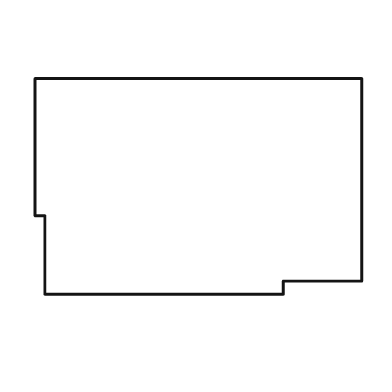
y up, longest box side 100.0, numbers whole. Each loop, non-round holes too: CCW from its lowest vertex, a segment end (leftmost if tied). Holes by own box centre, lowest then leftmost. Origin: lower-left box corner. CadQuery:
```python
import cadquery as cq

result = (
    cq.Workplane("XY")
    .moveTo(3.0, 0.0)
    .lineTo(76.0, 0.0)
    .lineTo(76.0, 4.0)
    .lineTo(100.0, 4.0)
    .lineTo(100.0, 66.0)
    .lineTo(0.0, 66.0)
    .lineTo(0.0, 24.0)
    .lineTo(3.0, 24.0)
    .close()
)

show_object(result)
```